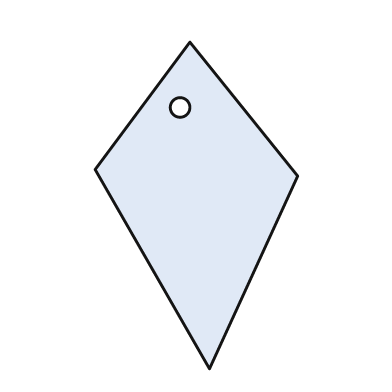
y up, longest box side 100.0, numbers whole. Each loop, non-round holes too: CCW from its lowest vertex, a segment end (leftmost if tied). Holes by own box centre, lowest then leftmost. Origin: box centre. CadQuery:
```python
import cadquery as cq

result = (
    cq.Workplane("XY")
    .moveTo(4.0, -50.0)
    .lineTo(31.0, 9.0)
    .lineTo(-2.0, 50.0)
    .lineTo(-31.0, 11.0)
    .close()
    .moveTo(-5.0, 30.0)
    .circle(3.0)
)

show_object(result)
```